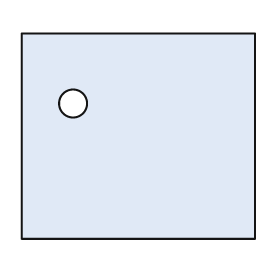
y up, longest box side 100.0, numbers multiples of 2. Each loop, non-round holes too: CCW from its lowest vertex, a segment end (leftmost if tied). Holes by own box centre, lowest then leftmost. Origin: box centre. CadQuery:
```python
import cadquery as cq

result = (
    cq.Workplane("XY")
    .moveTo(-50.0, -44.0)
    .lineTo(50.0, -44.0)
    .lineTo(50.0, 44.0)
    .lineTo(-50.0, 44.0)
    .close()
    .moveTo(-28.0, 14.0)
    .circle(6.0)
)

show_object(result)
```